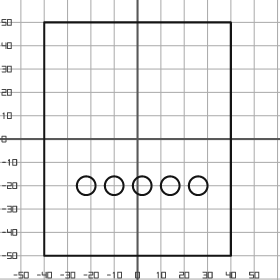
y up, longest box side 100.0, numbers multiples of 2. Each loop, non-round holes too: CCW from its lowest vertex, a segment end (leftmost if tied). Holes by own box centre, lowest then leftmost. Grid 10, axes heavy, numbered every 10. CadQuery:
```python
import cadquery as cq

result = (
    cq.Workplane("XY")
    .moveTo(-40.0, -50.0)
    .lineTo(40.0, -50.0)
    .lineTo(40.0, 50.0)
    .lineTo(-40.0, 50.0)
    .close()
    .moveTo(-22.0, -20.0)
    .circle(4.0)
    .moveTo(-10.0, -20.0)
    .circle(4.0)
    .moveTo(2.0, -20.0)
    .circle(4.0)
    .moveTo(14.0, -20.0)
    .circle(4.0)
    .moveTo(26.0, -20.0)
    .circle(4.0)
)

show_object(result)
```